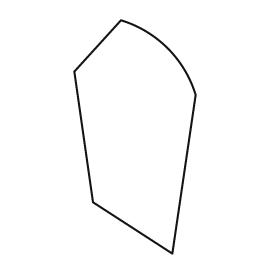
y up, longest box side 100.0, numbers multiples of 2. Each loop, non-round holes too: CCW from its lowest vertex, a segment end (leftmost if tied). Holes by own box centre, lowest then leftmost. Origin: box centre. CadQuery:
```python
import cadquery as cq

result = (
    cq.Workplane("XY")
    .moveTo(16.0, -50.0)
    .lineTo(26.0, 18.0)
    .threePointArc((14.0, 38.0), (-6.0, 50.0))
    .lineTo(-26.0, 28.0)
    .lineTo(-18.0, -28.0)
    .close()
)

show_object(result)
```